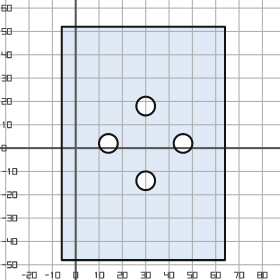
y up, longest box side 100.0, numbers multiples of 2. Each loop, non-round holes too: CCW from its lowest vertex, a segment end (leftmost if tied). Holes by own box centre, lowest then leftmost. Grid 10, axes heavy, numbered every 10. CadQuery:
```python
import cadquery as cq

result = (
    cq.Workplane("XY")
    .moveTo(-6.0, -48.0)
    .lineTo(64.0, -48.0)
    .lineTo(64.0, 52.0)
    .lineTo(-6.0, 52.0)
    .close()
    .moveTo(30.0, -14.0)
    .circle(4.0)
    .moveTo(14.0, 2.0)
    .circle(4.0)
    .moveTo(46.0, 2.0)
    .circle(4.0)
    .moveTo(30.0, 18.0)
    .circle(4.0)
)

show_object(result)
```